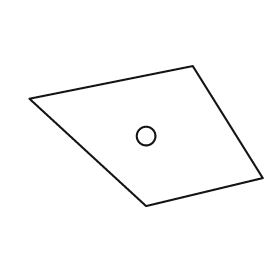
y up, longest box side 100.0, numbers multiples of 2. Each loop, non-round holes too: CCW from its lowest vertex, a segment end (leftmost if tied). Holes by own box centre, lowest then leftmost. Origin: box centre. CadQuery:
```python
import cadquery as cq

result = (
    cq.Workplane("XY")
    .moveTo(0.0, -30.0)
    .lineTo(50.0, -18.0)
    .lineTo(20.0, 30.0)
    .lineTo(-50.0, 16.0)
    .close()
    .moveTo(0.0, 0.0)
    .circle(4.0)
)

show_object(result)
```